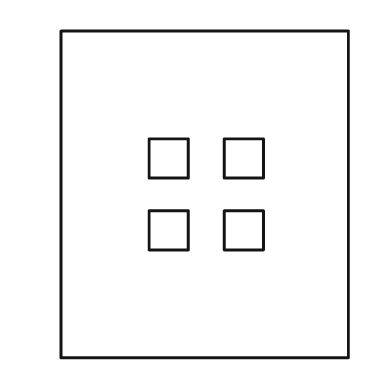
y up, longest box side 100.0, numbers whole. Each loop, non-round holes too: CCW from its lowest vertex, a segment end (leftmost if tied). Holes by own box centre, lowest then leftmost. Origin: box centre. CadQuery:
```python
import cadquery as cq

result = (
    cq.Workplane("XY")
    .moveTo(-44.0, -50.0)
    .lineTo(44.0, -50.0)
    .lineTo(44.0, 50.0)
    .lineTo(-44.0, 50.0)
    .close()
    .moveTo(-17.0, -17.0)
    .lineTo(-5.0, -17.0)
    .lineTo(-5.0, -5.0)
    .lineTo(-17.0, -5.0)
    .close()
    .moveTo(6.0, -17.0)
    .lineTo(18.0, -17.0)
    .lineTo(18.0, -5.0)
    .lineTo(6.0, -5.0)
    .close()
    .moveTo(-17.0, 5.0)
    .lineTo(-5.0, 5.0)
    .lineTo(-5.0, 17.0)
    .lineTo(-17.0, 17.0)
    .close()
    .moveTo(6.0, 5.0)
    .lineTo(18.0, 5.0)
    .lineTo(18.0, 17.0)
    .lineTo(6.0, 17.0)
    .close()
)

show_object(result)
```